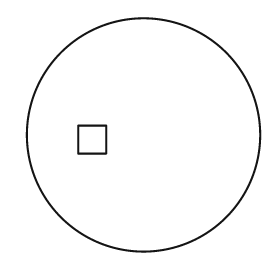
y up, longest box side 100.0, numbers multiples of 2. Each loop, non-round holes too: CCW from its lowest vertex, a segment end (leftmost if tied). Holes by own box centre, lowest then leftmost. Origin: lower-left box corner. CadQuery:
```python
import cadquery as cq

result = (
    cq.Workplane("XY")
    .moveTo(50.0, 50.0)
    .circle(50.0)
    .moveTo(22.0, 42.0)
    .lineTo(34.0, 42.0)
    .lineTo(34.0, 54.0)
    .lineTo(22.0, 54.0)
    .close()
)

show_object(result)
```